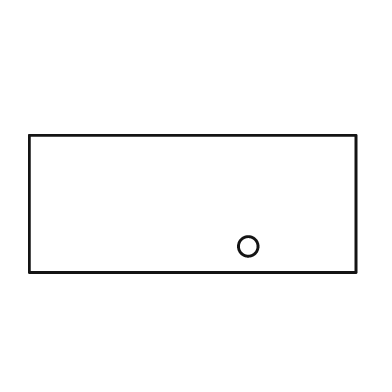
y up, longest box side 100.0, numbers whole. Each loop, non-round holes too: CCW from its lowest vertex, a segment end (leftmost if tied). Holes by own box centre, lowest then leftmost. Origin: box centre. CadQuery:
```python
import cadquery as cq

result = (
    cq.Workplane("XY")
    .moveTo(-50.0, -21.0)
    .lineTo(50.0, -21.0)
    .lineTo(50.0, 21.0)
    .lineTo(-50.0, 21.0)
    .close()
    .moveTo(17.0, -13.0)
    .circle(3.0)
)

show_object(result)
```